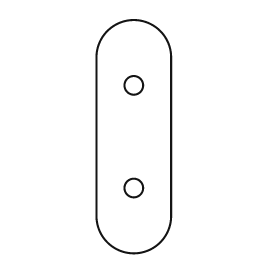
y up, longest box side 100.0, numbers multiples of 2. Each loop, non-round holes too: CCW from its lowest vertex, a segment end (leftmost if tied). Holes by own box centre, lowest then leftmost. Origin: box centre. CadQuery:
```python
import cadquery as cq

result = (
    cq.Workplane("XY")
    .moveTo(-16.0, -34.0)
    .threePointArc((0.0, -50.0), (16.0, -34.0))
    .lineTo(16.0, 34.0)
    .threePointArc((0.0, 50.0), (-16.0, 34.0))
    .close()
    .moveTo(0.0, -22.0)
    .circle(4.0)
    .moveTo(0.0, 22.0)
    .circle(4.0)
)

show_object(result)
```